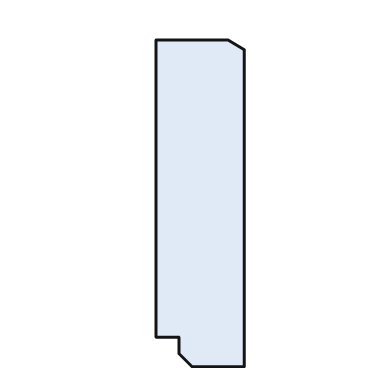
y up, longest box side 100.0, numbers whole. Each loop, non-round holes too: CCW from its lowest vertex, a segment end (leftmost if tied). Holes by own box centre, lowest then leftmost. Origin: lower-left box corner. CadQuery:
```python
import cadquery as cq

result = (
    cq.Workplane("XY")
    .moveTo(11.0, 0.0)
    .lineTo(27.0, 0.0)
    .lineTo(27.0, 97.0)
    .lineTo(22.0, 100.0)
    .lineTo(0.0, 100.0)
    .lineTo(0.0, 9.0)
    .lineTo(7.0, 9.0)
    .lineTo(7.0, 4.0)
    .close()
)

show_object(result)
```